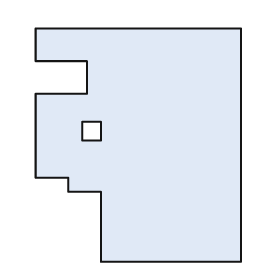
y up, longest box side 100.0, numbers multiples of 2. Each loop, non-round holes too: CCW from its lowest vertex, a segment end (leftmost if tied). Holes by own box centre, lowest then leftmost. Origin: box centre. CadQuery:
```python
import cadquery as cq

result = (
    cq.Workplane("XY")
    .moveTo(-16.0, -50.0)
    .lineTo(44.0, -50.0)
    .lineTo(44.0, 50.0)
    .lineTo(-44.0, 50.0)
    .lineTo(-44.0, 36.0)
    .lineTo(-22.0, 36.0)
    .lineTo(-22.0, 22.0)
    .lineTo(-44.0, 22.0)
    .lineTo(-44.0, -14.0)
    .lineTo(-30.0, -14.0)
    .lineTo(-30.0, -20.0)
    .lineTo(-16.0, -20.0)
    .close()
    .moveTo(-24.0, 2.0)
    .lineTo(-16.0, 2.0)
    .lineTo(-16.0, 10.0)
    .lineTo(-24.0, 10.0)
    .close()
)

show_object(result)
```